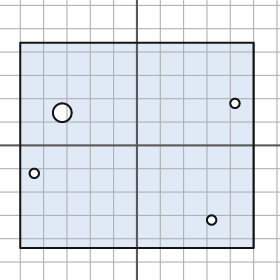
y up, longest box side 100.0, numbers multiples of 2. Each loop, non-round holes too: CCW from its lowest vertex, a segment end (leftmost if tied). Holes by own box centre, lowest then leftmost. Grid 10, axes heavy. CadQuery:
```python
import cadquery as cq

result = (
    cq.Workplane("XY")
    .moveTo(-50.0, -44.0)
    .lineTo(50.0, -44.0)
    .lineTo(50.0, 44.0)
    .lineTo(-50.0, 44.0)
    .close()
    .moveTo(32.0, -32.0)
    .circle(2.0)
    .moveTo(-44.0, -12.0)
    .circle(2.0)
    .moveTo(-32.0, 14.0)
    .circle(4.0)
    .moveTo(42.0, 18.0)
    .circle(2.0)
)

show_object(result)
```